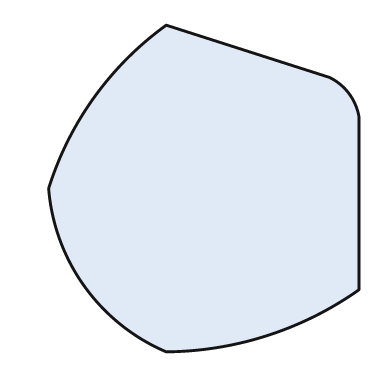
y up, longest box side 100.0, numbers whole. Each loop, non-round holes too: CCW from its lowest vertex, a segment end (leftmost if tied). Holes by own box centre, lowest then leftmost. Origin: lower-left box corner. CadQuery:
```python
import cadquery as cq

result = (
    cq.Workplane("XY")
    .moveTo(36.0, 0.0)
    .threePointArc((67.0, 5.0), (95.0, 19.0))
    .lineTo(95.0, 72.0)
    .threePointArc((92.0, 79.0), (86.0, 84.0))
    .lineTo(36.0, 100.0)
    .threePointArc((14.0, 78.0), (0.0, 50.0))
    .threePointArc((11.0, 20.0), (36.0, 0.0))
    .close()
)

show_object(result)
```